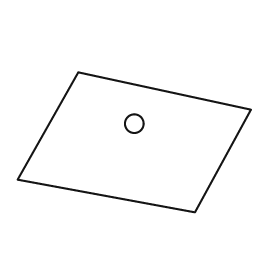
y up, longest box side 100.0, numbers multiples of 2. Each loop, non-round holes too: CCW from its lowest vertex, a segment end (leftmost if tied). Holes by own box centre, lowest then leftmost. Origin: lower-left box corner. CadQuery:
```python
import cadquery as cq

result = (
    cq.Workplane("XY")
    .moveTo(76.0, 0.0)
    .lineTo(100.0, 44.0)
    .lineTo(26.0, 60.0)
    .lineTo(0.0, 14.0)
    .close()
    .moveTo(50.0, 38.0)
    .circle(4.0)
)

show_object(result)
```